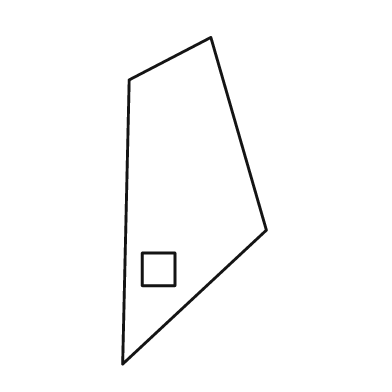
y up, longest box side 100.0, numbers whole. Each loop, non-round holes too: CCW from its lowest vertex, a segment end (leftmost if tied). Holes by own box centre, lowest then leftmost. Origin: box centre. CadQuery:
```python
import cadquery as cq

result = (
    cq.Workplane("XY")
    .moveTo(-22.0, -50.0)
    .lineTo(22.0, -9.0)
    .lineTo(5.0, 50.0)
    .lineTo(-20.0, 37.0)
    .close()
    .moveTo(-16.0, -26.0)
    .lineTo(-6.0, -26.0)
    .lineTo(-6.0, -16.0)
    .lineTo(-16.0, -16.0)
    .close()
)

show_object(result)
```